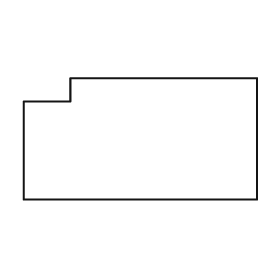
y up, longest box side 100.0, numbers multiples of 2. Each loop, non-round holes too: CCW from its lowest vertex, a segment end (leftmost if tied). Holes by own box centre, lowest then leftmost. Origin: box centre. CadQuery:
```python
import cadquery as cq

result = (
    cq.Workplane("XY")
    .moveTo(-50.0, -26.0)
    .lineTo(50.0, -26.0)
    .lineTo(50.0, 26.0)
    .lineTo(-30.0, 26.0)
    .lineTo(-30.0, 16.0)
    .lineTo(-50.0, 16.0)
    .close()
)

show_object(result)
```